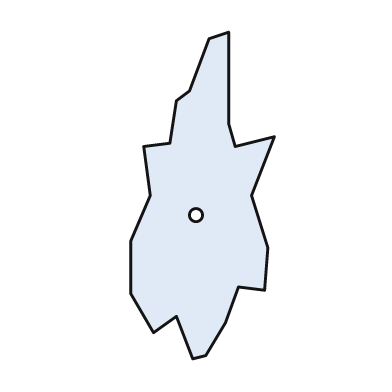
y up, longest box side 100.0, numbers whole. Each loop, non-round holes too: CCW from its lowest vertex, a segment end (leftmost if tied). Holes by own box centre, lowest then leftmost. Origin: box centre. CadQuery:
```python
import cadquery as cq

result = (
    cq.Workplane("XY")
    .moveTo(-3.0, -50.0)
    .lineTo(1.0, -49.0)
    .lineTo(7.0, -39.0)
    .lineTo(11.0, -28.0)
    .lineTo(19.0, -29.0)
    .lineTo(20.0, -16.0)
    .lineTo(15.0, 0.0)
    .lineTo(22.0, 18.0)
    .lineTo(10.0, 15.0)
    .lineTo(8.0, 22.0)
    .lineTo(8.0, 50.0)
    .lineTo(2.0, 48.0)
    .lineTo(-4.0, 32.0)
    .lineTo(-8.0, 29.0)
    .lineTo(-10.0, 16.0)
    .lineTo(-18.0, 15.0)
    .lineTo(-16.0, 0.0)
    .lineTo(-22.0, -14.0)
    .lineTo(-22.0, -30.0)
    .lineTo(-15.0, -42.0)
    .lineTo(-8.0, -37.0)
    .close()
    .moveTo(-2.0, -6.0)
    .circle(2.0)
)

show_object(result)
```